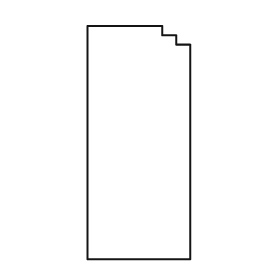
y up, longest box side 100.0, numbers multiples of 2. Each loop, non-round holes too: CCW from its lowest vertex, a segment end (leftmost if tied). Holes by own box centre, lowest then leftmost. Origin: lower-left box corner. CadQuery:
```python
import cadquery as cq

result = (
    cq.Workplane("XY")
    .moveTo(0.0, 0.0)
    .lineTo(44.0, 0.0)
    .lineTo(44.0, 92.0)
    .lineTo(38.0, 92.0)
    .lineTo(38.0, 96.0)
    .lineTo(32.0, 96.0)
    .lineTo(32.0, 100.0)
    .lineTo(0.0, 100.0)
    .close()
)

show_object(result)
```